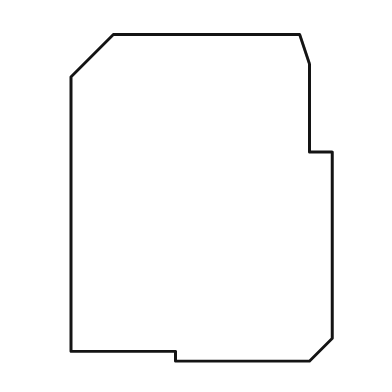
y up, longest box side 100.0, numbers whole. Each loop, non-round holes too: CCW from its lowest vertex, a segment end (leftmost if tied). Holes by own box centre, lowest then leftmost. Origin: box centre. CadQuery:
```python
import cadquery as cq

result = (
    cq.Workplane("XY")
    .moveTo(-8.0, -50.0)
    .lineTo(33.0, -50.0)
    .lineTo(40.0, -43.0)
    .lineTo(40.0, 14.0)
    .lineTo(33.0, 14.0)
    .lineTo(33.0, 41.0)
    .lineTo(30.0, 50.0)
    .lineTo(-27.0, 50.0)
    .lineTo(-40.0, 37.0)
    .lineTo(-40.0, -47.0)
    .lineTo(-8.0, -47.0)
    .close()
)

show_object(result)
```